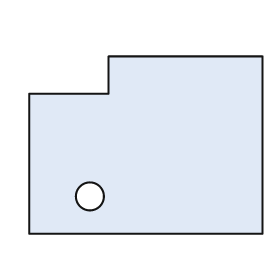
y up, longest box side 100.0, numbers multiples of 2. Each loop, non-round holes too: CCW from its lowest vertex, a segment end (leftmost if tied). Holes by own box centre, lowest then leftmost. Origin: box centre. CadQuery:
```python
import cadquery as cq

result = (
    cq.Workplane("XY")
    .moveTo(-50.0, -38.0)
    .lineTo(50.0, -38.0)
    .lineTo(50.0, 38.0)
    .lineTo(-16.0, 38.0)
    .lineTo(-16.0, 22.0)
    .lineTo(-50.0, 22.0)
    .close()
    .moveTo(-24.0, -22.0)
    .circle(6.0)
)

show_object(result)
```